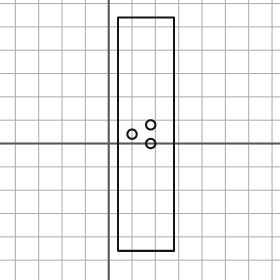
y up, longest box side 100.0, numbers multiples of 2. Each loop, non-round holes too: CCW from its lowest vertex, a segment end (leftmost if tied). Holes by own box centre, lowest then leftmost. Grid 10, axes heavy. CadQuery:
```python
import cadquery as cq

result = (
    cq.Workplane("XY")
    .moveTo(4.0, -46.0)
    .lineTo(28.0, -46.0)
    .lineTo(28.0, 54.0)
    .lineTo(4.0, 54.0)
    .close()
    .moveTo(18.0, 0.0)
    .circle(2.0)
    .moveTo(10.0, 4.0)
    .circle(2.0)
    .moveTo(18.0, 8.0)
    .circle(2.0)
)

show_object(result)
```